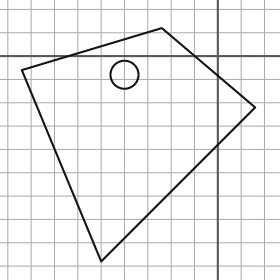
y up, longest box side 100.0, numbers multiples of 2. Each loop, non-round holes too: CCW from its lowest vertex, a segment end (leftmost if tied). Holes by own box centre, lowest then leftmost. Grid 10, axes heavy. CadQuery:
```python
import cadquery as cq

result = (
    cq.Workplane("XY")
    .moveTo(-50.0, -88.0)
    .lineTo(16.0, -22.0)
    .lineTo(-24.0, 12.0)
    .lineTo(-84.0, -6.0)
    .close()
    .moveTo(-40.0, -8.0)
    .circle(6.0)
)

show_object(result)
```